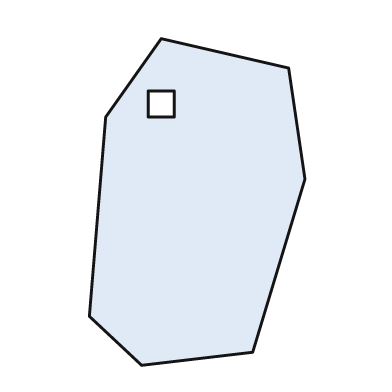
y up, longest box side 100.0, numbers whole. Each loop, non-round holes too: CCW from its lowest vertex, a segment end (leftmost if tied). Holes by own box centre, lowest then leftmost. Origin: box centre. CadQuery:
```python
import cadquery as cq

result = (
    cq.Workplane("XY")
    .moveTo(-17.0, -50.0)
    .lineTo(17.0, -46.0)
    .lineTo(33.0, 7.0)
    .lineTo(28.0, 41.0)
    .lineTo(-11.0, 50.0)
    .lineTo(-28.0, 26.0)
    .lineTo(-33.0, -35.0)
    .close()
    .moveTo(-15.0, 26.0)
    .lineTo(-7.0, 26.0)
    .lineTo(-7.0, 34.0)
    .lineTo(-15.0, 34.0)
    .close()
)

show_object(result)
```